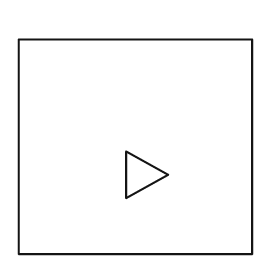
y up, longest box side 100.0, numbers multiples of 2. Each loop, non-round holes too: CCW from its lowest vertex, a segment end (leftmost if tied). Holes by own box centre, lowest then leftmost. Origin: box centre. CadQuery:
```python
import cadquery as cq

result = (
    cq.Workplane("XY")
    .moveTo(-50.0, -46.0)
    .lineTo(50.0, -46.0)
    .lineTo(50.0, 46.0)
    .lineTo(-50.0, 46.0)
    .close()
    .moveTo(-4.0, -22.0)
    .lineTo(14.0, -12.0)
    .lineTo(-4.0, -2.0)
    .close()
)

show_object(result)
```